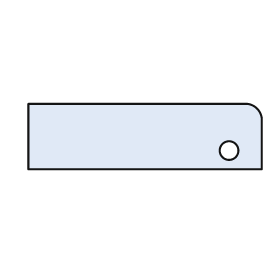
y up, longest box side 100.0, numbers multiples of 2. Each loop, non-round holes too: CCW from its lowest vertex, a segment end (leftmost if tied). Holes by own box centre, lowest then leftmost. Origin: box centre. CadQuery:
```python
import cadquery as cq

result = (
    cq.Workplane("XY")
    .moveTo(-50.0, -14.0)
    .lineTo(50.0, -14.0)
    .lineTo(50.0, 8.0)
    .threePointArc((48.0, 12.0), (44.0, 14.0))
    .lineTo(-50.0, 14.0)
    .close()
    .moveTo(36.0, -6.0)
    .circle(4.0)
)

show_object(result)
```